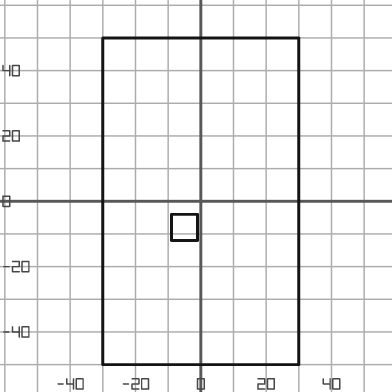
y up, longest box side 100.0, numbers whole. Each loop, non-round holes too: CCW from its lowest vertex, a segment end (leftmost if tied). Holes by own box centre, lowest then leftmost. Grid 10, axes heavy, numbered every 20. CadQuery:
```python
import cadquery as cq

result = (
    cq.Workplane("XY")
    .moveTo(-30.0, -50.0)
    .lineTo(30.0, -50.0)
    .lineTo(30.0, 50.0)
    .lineTo(-30.0, 50.0)
    .close()
    .moveTo(-9.0, -12.0)
    .lineTo(-1.0, -12.0)
    .lineTo(-1.0, -4.0)
    .lineTo(-9.0, -4.0)
    .close()
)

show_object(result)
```